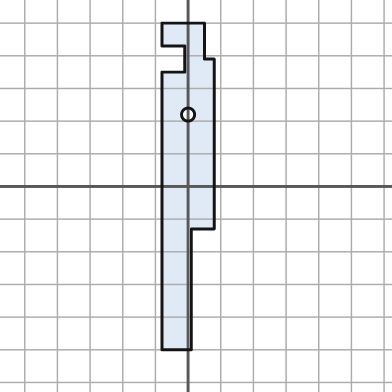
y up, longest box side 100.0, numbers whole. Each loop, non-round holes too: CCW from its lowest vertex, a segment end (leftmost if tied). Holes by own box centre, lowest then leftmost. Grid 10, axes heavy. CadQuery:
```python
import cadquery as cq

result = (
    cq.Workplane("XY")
    .moveTo(-8.0, -50.0)
    .lineTo(1.0, -50.0)
    .lineTo(1.0, -13.0)
    .lineTo(8.0, -13.0)
    .lineTo(8.0, 39.0)
    .lineTo(5.0, 39.0)
    .lineTo(5.0, 50.0)
    .lineTo(-8.0, 50.0)
    .lineTo(-8.0, 43.0)
    .lineTo(-1.0, 43.0)
    .lineTo(-1.0, 35.0)
    .lineTo(-8.0, 35.0)
    .close()
    .moveTo(0.0, 22.0)
    .circle(2.0)
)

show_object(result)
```